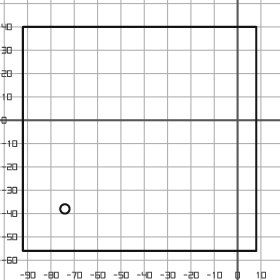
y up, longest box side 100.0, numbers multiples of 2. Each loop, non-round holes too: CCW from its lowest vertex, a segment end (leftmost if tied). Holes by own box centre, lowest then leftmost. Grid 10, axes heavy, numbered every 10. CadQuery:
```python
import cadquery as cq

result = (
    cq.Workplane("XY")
    .moveTo(-92.0, -56.0)
    .lineTo(8.0, -56.0)
    .lineTo(8.0, 40.0)
    .lineTo(-92.0, 40.0)
    .close()
    .moveTo(-74.0, -38.0)
    .circle(2.0)
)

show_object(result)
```